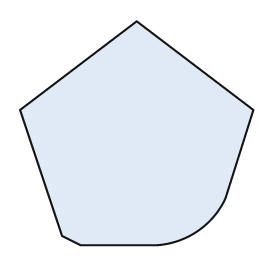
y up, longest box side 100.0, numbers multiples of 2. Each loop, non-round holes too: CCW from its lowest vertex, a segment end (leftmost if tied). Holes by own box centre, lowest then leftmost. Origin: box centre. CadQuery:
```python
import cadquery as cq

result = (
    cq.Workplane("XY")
    .moveTo(-24.0, -48.0)
    .lineTo(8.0, -48.0)
    .threePointArc((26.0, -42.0), (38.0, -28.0))
    .lineTo(50.0, 10.0)
    .lineTo(0.0, 48.0)
    .lineTo(-50.0, 10.0)
    .lineTo(-32.0, -44.0)
    .close()
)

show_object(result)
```